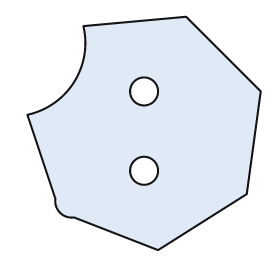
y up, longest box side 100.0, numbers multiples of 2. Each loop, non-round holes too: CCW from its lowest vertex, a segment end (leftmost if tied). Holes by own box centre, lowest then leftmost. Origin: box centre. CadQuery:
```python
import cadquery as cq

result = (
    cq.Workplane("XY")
    .moveTo(6.0, -50.0)
    .lineTo(44.0, -26.0)
    .lineTo(50.0, 18.0)
    .lineTo(18.0, 50.0)
    .lineTo(-26.0, 46.0)
    .threePointArc((-30.0, 22.0), (-50.0, 8.0))
    .lineTo(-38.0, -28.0)
    .threePointArc((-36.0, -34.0), (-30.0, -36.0))
    .close()
    .moveTo(0.0, -16.0)
    .circle(6.0)
    .moveTo(0.0, 18.0)
    .circle(6.0)
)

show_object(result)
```